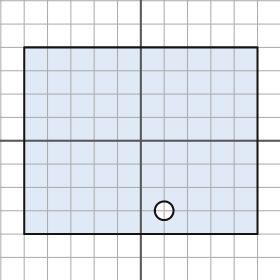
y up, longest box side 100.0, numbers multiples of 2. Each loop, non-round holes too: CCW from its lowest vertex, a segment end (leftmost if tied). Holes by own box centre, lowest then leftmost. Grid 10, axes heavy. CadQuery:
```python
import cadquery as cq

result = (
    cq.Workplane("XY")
    .moveTo(-50.0, -40.0)
    .lineTo(50.0, -40.0)
    .lineTo(50.0, 40.0)
    .lineTo(-50.0, 40.0)
    .close()
    .moveTo(10.0, -30.0)
    .circle(4.0)
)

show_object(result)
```